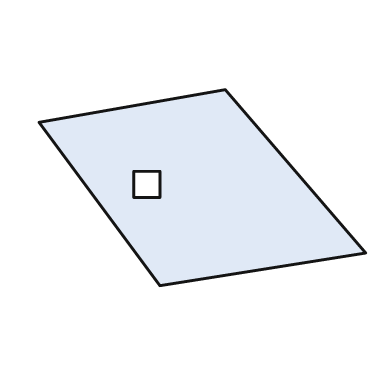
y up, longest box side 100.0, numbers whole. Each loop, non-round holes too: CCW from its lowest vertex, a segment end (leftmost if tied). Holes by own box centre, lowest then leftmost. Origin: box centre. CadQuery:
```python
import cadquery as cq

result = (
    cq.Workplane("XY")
    .moveTo(-13.0, -30.0)
    .lineTo(50.0, -20.0)
    .lineTo(7.0, 30.0)
    .lineTo(-50.0, 20.0)
    .close()
    .moveTo(-21.0, -3.0)
    .lineTo(-13.0, -3.0)
    .lineTo(-13.0, 5.0)
    .lineTo(-21.0, 5.0)
    .close()
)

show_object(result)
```